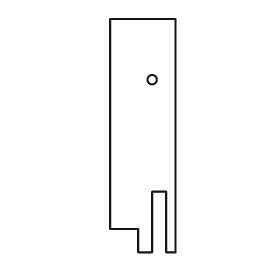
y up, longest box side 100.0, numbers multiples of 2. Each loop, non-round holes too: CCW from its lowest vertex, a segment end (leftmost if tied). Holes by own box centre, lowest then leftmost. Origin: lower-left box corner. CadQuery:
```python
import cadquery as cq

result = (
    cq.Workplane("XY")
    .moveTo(12.0, 0.0)
    .lineTo(18.0, 0.0)
    .lineTo(18.0, 26.0)
    .lineTo(24.0, 26.0)
    .lineTo(24.0, 0.0)
    .lineTo(28.0, 0.0)
    .lineTo(28.0, 100.0)
    .lineTo(0.0, 100.0)
    .lineTo(0.0, 10.0)
    .lineTo(12.0, 10.0)
    .close()
    .moveTo(18.0, 74.0)
    .circle(2.0)
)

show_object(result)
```